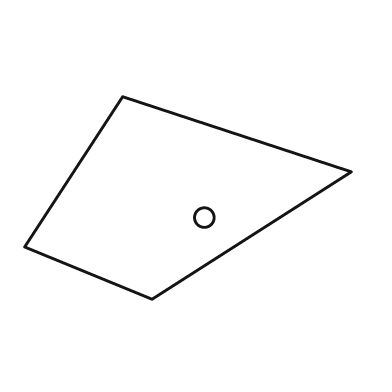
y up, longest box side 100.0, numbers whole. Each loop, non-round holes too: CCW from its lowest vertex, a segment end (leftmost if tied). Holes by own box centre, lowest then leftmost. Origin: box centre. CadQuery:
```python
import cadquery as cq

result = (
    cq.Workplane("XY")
    .moveTo(-11.0, -31.0)
    .lineTo(50.0, 8.0)
    .lineTo(-20.0, 31.0)
    .lineTo(-50.0, -15.0)
    .close()
    .moveTo(5.0, -6.0)
    .circle(3.0)
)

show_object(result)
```